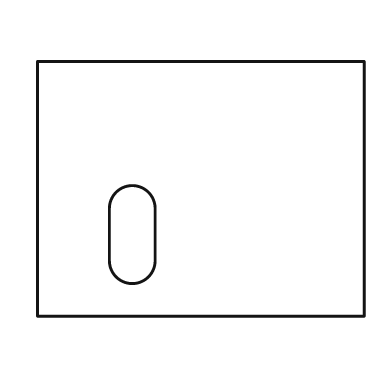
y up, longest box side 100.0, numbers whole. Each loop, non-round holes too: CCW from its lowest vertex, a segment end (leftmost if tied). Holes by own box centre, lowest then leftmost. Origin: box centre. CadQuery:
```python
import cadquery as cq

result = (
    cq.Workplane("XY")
    .moveTo(-50.0, -39.0)
    .lineTo(50.0, -39.0)
    .lineTo(50.0, 39.0)
    .lineTo(-50.0, 39.0)
    .close()
    .moveTo(-28.0, -22.0)
    .threePointArc((-21.0, -29.0), (-14.0, -22.0))
    .lineTo(-14.0, -6.0)
    .threePointArc((-21.0, 1.0), (-28.0, -6.0))
    .close()
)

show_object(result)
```